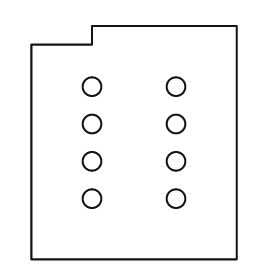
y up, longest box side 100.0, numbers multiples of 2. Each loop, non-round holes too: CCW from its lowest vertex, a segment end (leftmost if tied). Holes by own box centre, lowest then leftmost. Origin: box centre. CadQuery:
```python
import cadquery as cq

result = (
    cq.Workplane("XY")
    .moveTo(-44.0, -50.0)
    .lineTo(44.0, -50.0)
    .lineTo(44.0, 50.0)
    .lineTo(-18.0, 50.0)
    .lineTo(-18.0, 42.0)
    .lineTo(-44.0, 42.0)
    .close()
    .moveTo(-18.0, -24.0)
    .circle(4.0)
    .moveTo(18.0, -24.0)
    .circle(4.0)
    .moveTo(-18.0, -8.0)
    .circle(4.0)
    .moveTo(18.0, -8.0)
    .circle(4.0)
    .moveTo(-18.0, 8.0)
    .circle(4.0)
    .moveTo(18.0, 8.0)
    .circle(4.0)
    .moveTo(-18.0, 24.0)
    .circle(4.0)
    .moveTo(18.0, 24.0)
    .circle(4.0)
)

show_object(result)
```